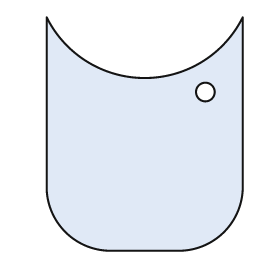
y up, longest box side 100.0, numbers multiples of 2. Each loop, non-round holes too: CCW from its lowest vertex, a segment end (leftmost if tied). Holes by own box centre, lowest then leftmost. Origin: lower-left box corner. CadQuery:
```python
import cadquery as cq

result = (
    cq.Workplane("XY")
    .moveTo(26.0, 0.0)
    .lineTo(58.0, 0.0)
    .threePointArc((76.0, 8.0), (84.0, 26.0))
    .lineTo(84.0, 100.0)
    .threePointArc((42.0, 74.0), (0.0, 100.0))
    .lineTo(0.0, 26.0)
    .threePointArc((8.0, 8.0), (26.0, 0.0))
    .close()
    .moveTo(68.0, 68.0)
    .circle(4.0)
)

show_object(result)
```